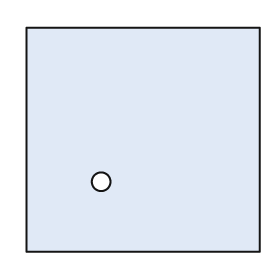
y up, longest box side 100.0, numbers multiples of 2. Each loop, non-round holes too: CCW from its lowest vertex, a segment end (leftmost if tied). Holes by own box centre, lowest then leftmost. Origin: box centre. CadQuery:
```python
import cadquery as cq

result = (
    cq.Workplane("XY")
    .moveTo(-50.0, -48.0)
    .lineTo(50.0, -48.0)
    .lineTo(50.0, 48.0)
    .lineTo(-50.0, 48.0)
    .close()
    .moveTo(-18.0, -18.0)
    .circle(4.0)
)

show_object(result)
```